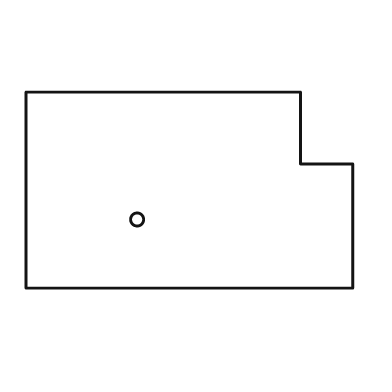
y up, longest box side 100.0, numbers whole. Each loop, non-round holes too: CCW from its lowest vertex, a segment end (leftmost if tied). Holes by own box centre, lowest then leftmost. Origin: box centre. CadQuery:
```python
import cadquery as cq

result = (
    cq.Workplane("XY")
    .moveTo(-50.0, -30.0)
    .lineTo(50.0, -30.0)
    .lineTo(50.0, 8.0)
    .lineTo(34.0, 8.0)
    .lineTo(34.0, 30.0)
    .lineTo(-50.0, 30.0)
    .close()
    .moveTo(-16.0, -9.0)
    .circle(2.0)
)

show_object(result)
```